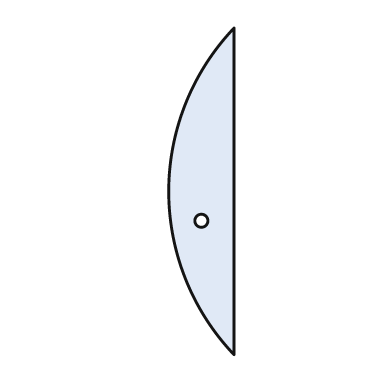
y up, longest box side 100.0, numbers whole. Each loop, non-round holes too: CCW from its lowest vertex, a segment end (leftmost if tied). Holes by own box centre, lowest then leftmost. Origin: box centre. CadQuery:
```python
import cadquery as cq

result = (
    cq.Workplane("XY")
    .moveTo(10.0, -50.0)
    .lineTo(10.0, 50.0)
    .threePointArc((-10.0, 0.0), (10.0, -50.0))
    .close()
    .moveTo(0.0, -9.0)
    .circle(2.0)
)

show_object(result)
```